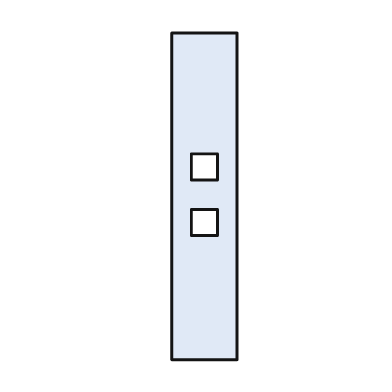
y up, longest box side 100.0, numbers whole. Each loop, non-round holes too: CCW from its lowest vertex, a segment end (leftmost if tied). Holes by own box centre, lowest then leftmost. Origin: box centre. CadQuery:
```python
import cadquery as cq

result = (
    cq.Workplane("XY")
    .moveTo(-10.0, -50.0)
    .lineTo(10.0, -50.0)
    .lineTo(10.0, 50.0)
    .lineTo(-10.0, 50.0)
    .close()
    .moveTo(-4.0, -12.0)
    .lineTo(4.0, -12.0)
    .lineTo(4.0, -4.0)
    .lineTo(-4.0, -4.0)
    .close()
    .moveTo(-4.0, 5.0)
    .lineTo(4.0, 5.0)
    .lineTo(4.0, 13.0)
    .lineTo(-4.0, 13.0)
    .close()
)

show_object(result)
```